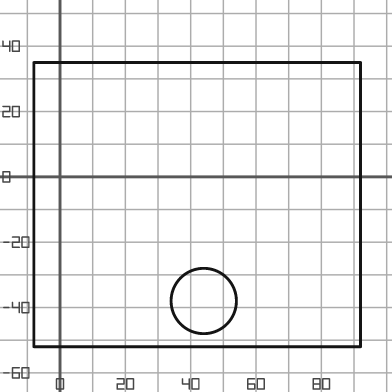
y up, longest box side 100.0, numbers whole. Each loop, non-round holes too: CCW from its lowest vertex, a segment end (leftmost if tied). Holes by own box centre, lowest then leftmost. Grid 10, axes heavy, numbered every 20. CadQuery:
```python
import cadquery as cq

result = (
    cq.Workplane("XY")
    .moveTo(-8.0, -52.0)
    .lineTo(92.0, -52.0)
    .lineTo(92.0, 35.0)
    .lineTo(-8.0, 35.0)
    .close()
    .moveTo(44.0, -38.0)
    .circle(10.0)
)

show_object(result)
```